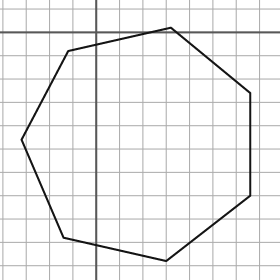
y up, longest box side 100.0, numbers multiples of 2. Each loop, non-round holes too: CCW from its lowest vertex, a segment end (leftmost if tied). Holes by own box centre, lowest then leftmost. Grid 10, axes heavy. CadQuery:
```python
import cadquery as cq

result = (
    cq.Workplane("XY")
    .moveTo(30.0, -98.0)
    .lineTo(66.0, -70.0)
    .lineTo(66.0, -26.0)
    .lineTo(32.0, 2.0)
    .lineTo(-12.0, -8.0)
    .lineTo(-32.0, -46.0)
    .lineTo(-14.0, -88.0)
    .close()
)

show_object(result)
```